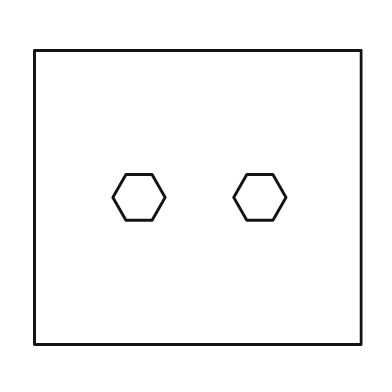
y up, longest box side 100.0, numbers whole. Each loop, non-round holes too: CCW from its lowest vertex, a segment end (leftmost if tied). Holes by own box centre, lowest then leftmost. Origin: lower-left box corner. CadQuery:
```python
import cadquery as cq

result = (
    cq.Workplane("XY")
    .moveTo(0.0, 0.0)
    .lineTo(100.0, 0.0)
    .lineTo(100.0, 90.0)
    .lineTo(0.0, 90.0)
    .close()
    .moveTo(28.0, 38.0)
    .lineTo(36.0, 38.0)
    .lineTo(40.0, 45.0)
    .lineTo(36.0, 52.0)
    .lineTo(28.0, 52.0)
    .lineTo(24.0, 45.0)
    .close()
    .moveTo(65.0, 38.0)
    .lineTo(73.0, 38.0)
    .lineTo(77.0, 45.0)
    .lineTo(73.0, 52.0)
    .lineTo(65.0, 52.0)
    .lineTo(61.0, 45.0)
    .close()
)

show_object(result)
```